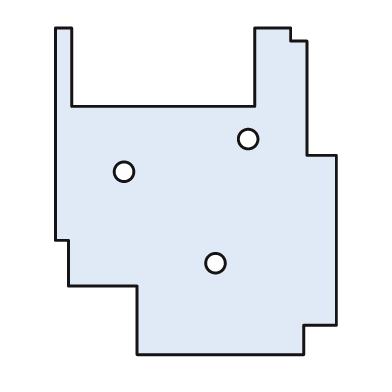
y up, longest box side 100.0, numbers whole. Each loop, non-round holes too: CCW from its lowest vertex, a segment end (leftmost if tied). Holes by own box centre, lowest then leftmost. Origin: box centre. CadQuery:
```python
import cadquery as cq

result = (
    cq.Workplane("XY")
    .moveTo(-18.0, -50.0)
    .lineTo(33.0, -50.0)
    .lineTo(33.0, -41.0)
    .lineTo(43.0, -41.0)
    .lineTo(43.0, 11.0)
    .lineTo(34.0, 11.0)
    .lineTo(34.0, 46.0)
    .lineTo(29.0, 46.0)
    .lineTo(29.0, 50.0)
    .lineTo(18.0, 50.0)
    .lineTo(18.0, 26.0)
    .lineTo(-38.0, 26.0)
    .lineTo(-38.0, 50.0)
    .lineTo(-43.0, 50.0)
    .lineTo(-43.0, -15.0)
    .lineTo(-39.0, -15.0)
    .lineTo(-39.0, -29.0)
    .lineTo(-18.0, -29.0)
    .close()
    .moveTo(6.0, -22.0)
    .circle(3.0)
    .moveTo(-22.0, 6.0)
    .circle(3.0)
    .moveTo(16.0, 16.0)
    .circle(3.0)
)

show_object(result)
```